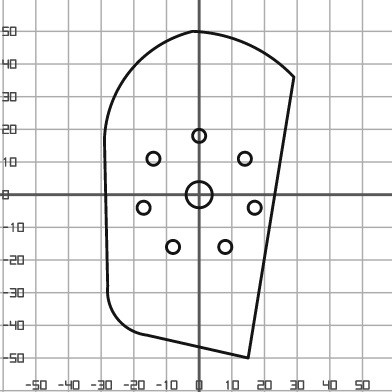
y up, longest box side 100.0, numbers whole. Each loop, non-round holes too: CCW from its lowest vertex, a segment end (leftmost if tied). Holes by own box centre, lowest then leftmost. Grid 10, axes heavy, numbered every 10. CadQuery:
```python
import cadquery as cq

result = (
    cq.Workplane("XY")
    .moveTo(15.0, -50.0)
    .lineTo(29.0, 36.0)
    .threePointArc((15.0, 46.0), (-2.0, 50.0))
    .threePointArc((-21.0, 38.0), (-29.0, 17.0))
    .lineTo(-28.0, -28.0)
    .threePointArc((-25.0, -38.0), (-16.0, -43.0))
    .close()
    .moveTo(-8.0, -16.0)
    .circle(2.0)
    .moveTo(8.0, -16.0)
    .circle(2.0)
    .moveTo(-17.0, -4.0)
    .circle(2.0)
    .moveTo(17.0, -4.0)
    .circle(2.0)
    .moveTo(0.0, 0.0)
    .circle(4.0)
    .moveTo(-14.0, 11.0)
    .circle(2.0)
    .moveTo(14.0, 11.0)
    .circle(2.0)
    .moveTo(0.0, 18.0)
    .circle(2.0)
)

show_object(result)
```